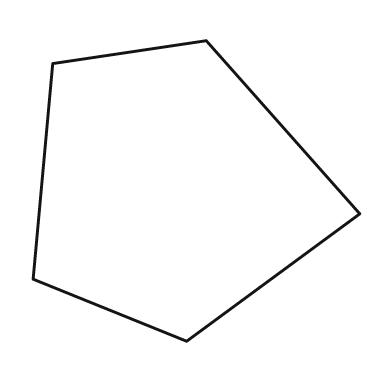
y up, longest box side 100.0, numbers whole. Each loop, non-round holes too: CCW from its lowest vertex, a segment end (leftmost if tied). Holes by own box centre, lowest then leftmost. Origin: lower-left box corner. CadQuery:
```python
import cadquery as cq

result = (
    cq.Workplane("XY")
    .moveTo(47.0, 0.0)
    .lineTo(100.0, 39.0)
    .lineTo(53.0, 92.0)
    .lineTo(6.0, 85.0)
    .lineTo(0.0, 19.0)
    .close()
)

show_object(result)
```